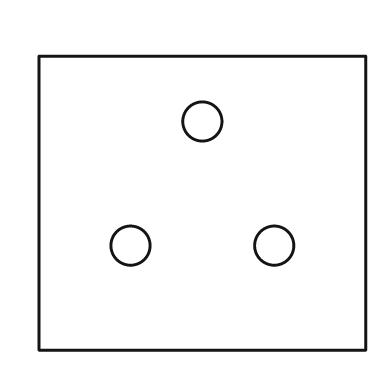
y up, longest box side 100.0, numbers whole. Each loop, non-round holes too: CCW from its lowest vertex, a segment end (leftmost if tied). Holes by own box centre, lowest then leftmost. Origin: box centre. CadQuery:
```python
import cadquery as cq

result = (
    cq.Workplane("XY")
    .moveTo(-50.0, -45.0)
    .lineTo(50.0, -45.0)
    .lineTo(50.0, 45.0)
    .lineTo(-50.0, 45.0)
    .close()
    .moveTo(-22.0, -13.0)
    .circle(6.0)
    .moveTo(22.0, -13.0)
    .circle(6.0)
    .moveTo(0.0, 25.0)
    .circle(6.0)
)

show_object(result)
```